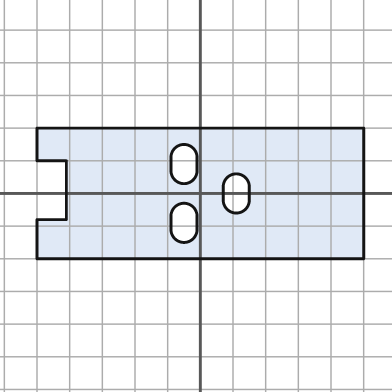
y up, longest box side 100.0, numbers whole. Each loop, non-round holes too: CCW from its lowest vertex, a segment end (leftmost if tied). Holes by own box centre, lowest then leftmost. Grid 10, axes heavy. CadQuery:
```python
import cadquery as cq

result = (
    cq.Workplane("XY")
    .moveTo(-50.0, -20.0)
    .lineTo(50.0, -20.0)
    .lineTo(50.0, 20.0)
    .lineTo(-50.0, 20.0)
    .lineTo(-50.0, 10.0)
    .lineTo(-41.0, 10.0)
    .lineTo(-41.0, -8.0)
    .lineTo(-50.0, -8.0)
    .close()
    .moveTo(-9.0, -11.0)
    .threePointArc((-5.0, -15.0), (-1.0, -11.0))
    .lineTo(-1.0, -7.0)
    .threePointArc((-5.0, -3.0), (-9.0, -7.0))
    .close()
    .moveTo(7.0, -2.0)
    .threePointArc((11.0, -6.0), (15.0, -2.0))
    .lineTo(15.0, 2.0)
    .threePointArc((11.0, 6.0), (7.0, 2.0))
    .close()
    .moveTo(-9.0, 7.0)
    .threePointArc((-5.0, 3.0), (-1.0, 7.0))
    .lineTo(-1.0, 11.0)
    .threePointArc((-5.0, 15.0), (-9.0, 11.0))
    .close()
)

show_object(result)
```